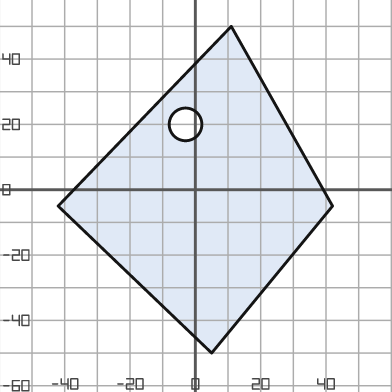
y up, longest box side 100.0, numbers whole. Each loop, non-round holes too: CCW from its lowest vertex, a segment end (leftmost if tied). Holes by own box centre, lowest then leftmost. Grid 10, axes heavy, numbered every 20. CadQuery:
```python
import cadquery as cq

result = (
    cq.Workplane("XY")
    .moveTo(5.0, -50.0)
    .lineTo(42.0, -5.0)
    .lineTo(11.0, 50.0)
    .lineTo(-42.0, -5.0)
    .close()
    .moveTo(-3.0, 20.0)
    .circle(5.0)
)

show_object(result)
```